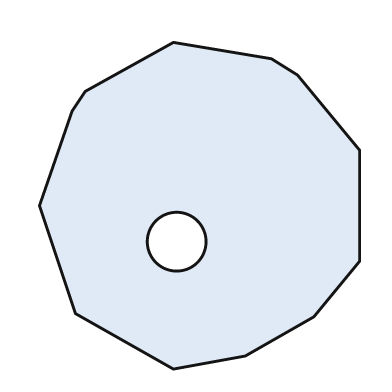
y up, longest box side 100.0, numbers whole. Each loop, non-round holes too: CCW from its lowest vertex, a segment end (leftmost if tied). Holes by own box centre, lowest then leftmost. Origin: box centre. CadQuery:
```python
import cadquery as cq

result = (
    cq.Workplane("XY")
    .moveTo(-8.0, -50.0)
    .lineTo(14.0, -46.0)
    .lineTo(35.0, -34.0)
    .lineTo(49.0, -17.0)
    .lineTo(49.0, 17.0)
    .lineTo(30.0, 40.0)
    .lineTo(22.0, 45.0)
    .lineTo(-8.0, 50.0)
    .lineTo(-35.0, 35.0)
    .lineTo(-39.0, 29.0)
    .lineTo(-49.0, 0.0)
    .lineTo(-38.0, -33.0)
    .close()
    .moveTo(-7.0, -11.0)
    .circle(9.0)
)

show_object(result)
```